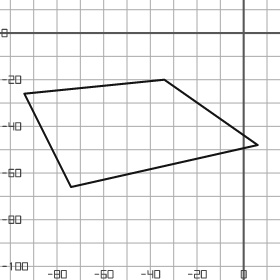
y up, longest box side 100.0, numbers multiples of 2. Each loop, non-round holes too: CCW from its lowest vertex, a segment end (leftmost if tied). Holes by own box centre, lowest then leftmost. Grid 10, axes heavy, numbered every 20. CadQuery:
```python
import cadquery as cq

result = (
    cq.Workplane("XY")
    .moveTo(-74.0, -66.0)
    .lineTo(6.0, -48.0)
    .lineTo(-34.0, -20.0)
    .lineTo(-94.0, -26.0)
    .close()
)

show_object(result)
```